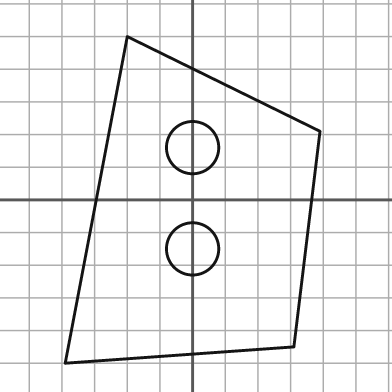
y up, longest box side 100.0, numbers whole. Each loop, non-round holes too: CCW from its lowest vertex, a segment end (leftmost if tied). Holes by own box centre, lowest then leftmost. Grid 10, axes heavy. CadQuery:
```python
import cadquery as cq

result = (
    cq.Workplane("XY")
    .moveTo(-39.0, -50.0)
    .lineTo(31.0, -45.0)
    .lineTo(39.0, 21.0)
    .lineTo(-20.0, 50.0)
    .close()
    .moveTo(0.0, -15.0)
    .circle(8.0)
    .moveTo(0.0, 16.0)
    .circle(8.0)
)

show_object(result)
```